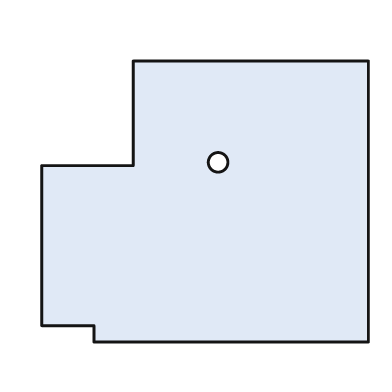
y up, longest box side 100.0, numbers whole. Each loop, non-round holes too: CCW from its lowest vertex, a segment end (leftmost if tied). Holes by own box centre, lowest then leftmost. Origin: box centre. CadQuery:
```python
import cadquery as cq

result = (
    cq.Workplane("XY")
    .moveTo(-34.0, -43.0)
    .lineTo(50.0, -43.0)
    .lineTo(50.0, 43.0)
    .lineTo(-22.0, 43.0)
    .lineTo(-22.0, 11.0)
    .lineTo(-50.0, 11.0)
    .lineTo(-50.0, -38.0)
    .lineTo(-34.0, -38.0)
    .close()
    .moveTo(4.0, 12.0)
    .circle(3.0)
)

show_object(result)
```